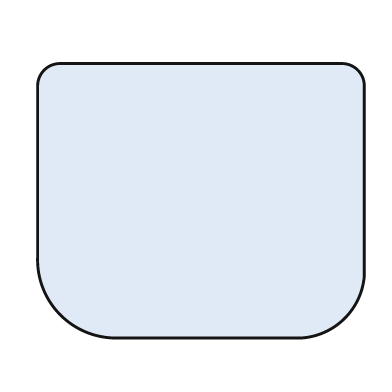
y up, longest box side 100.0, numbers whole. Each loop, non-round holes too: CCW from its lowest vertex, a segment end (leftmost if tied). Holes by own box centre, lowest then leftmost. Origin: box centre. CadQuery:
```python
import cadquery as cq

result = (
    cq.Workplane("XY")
    .moveTo(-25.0, -42.0)
    .lineTo(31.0, -42.0)
    .threePointArc((44.0, -36.0), (50.0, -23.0))
    .lineTo(50.0, 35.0)
    .threePointArc((48.0, 40.0), (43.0, 42.0))
    .lineTo(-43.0, 42.0)
    .threePointArc((-48.0, 40.0), (-50.0, 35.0))
    .lineTo(-50.0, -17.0)
    .threePointArc((-43.0, -35.0), (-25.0, -42.0))
    .close()
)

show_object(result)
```